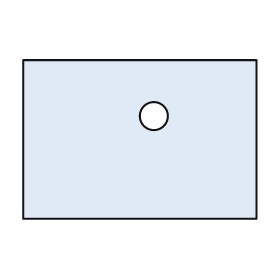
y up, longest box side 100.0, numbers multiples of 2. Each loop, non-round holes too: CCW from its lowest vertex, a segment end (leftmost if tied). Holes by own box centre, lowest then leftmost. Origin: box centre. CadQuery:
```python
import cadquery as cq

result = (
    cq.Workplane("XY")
    .moveTo(-50.0, -34.0)
    .lineTo(50.0, -34.0)
    .lineTo(50.0, 34.0)
    .lineTo(-50.0, 34.0)
    .close()
    .moveTo(6.0, 10.0)
    .circle(6.0)
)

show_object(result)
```